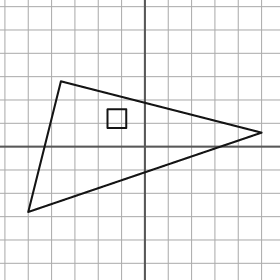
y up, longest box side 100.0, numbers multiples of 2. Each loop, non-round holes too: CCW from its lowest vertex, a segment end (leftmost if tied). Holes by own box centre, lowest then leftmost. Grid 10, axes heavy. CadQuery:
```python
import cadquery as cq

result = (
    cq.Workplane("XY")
    .moveTo(-50.0, -28.0)
    .lineTo(50.0, 6.0)
    .lineTo(-36.0, 28.0)
    .close()
    .moveTo(-16.0, 8.0)
    .lineTo(-8.0, 8.0)
    .lineTo(-8.0, 16.0)
    .lineTo(-16.0, 16.0)
    .close()
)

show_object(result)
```